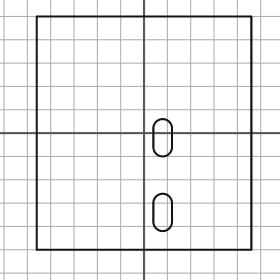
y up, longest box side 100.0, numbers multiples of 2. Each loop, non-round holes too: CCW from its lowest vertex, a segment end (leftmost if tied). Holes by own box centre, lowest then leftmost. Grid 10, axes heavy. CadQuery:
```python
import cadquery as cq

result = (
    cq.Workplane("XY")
    .moveTo(-46.0, -50.0)
    .lineTo(46.0, -50.0)
    .lineTo(46.0, 50.0)
    .lineTo(-46.0, 50.0)
    .close()
    .moveTo(4.0, -38.0)
    .threePointArc((8.0, -42.0), (12.0, -38.0))
    .lineTo(12.0, -30.0)
    .threePointArc((8.0, -26.0), (4.0, -30.0))
    .close()
    .moveTo(4.0, -6.0)
    .threePointArc((8.0, -10.0), (12.0, -6.0))
    .lineTo(12.0, 2.0)
    .threePointArc((8.0, 6.0), (4.0, 2.0))
    .close()
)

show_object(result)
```